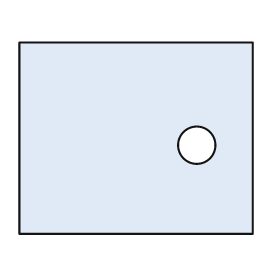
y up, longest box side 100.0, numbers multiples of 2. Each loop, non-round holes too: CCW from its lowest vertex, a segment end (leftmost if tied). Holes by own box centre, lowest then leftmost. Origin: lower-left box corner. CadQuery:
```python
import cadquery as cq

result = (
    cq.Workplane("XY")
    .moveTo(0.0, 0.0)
    .lineTo(100.0, 0.0)
    .lineTo(100.0, 82.0)
    .lineTo(0.0, 82.0)
    .close()
    .moveTo(76.0, 38.0)
    .circle(8.0)
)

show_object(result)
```